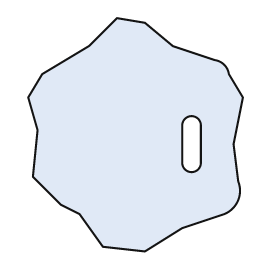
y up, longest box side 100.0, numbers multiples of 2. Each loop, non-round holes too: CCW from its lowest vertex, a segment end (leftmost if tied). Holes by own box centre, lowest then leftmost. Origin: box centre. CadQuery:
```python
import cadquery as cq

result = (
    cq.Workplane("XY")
    .moveTo(4.0, -50.0)
    .lineTo(20.0, -40.0)
    .lineTo(38.0, -34.0)
    .threePointArc((44.0, -28.0), (44.0, -20.0))
    .lineTo(42.0, -4.0)
    .lineTo(46.0, 16.0)
    .lineTo(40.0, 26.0)
    .threePointArc((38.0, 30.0), (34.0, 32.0))
    .lineTo(16.0, 38.0)
    .lineTo(4.0, 48.0)
    .lineTo(-8.0, 50.0)
    .lineTo(-20.0, 38.0)
    .lineTo(-40.0, 26.0)
    .lineTo(-46.0, 16.0)
    .lineTo(-42.0, 2.0)
    .lineTo(-44.0, -18.0)
    .lineTo(-32.0, -30.0)
    .lineTo(-24.0, -34.0)
    .lineTo(-14.0, -48.0)
    .close()
    .moveTo(20.0, -12.0)
    .threePointArc((24.0, -16.0), (28.0, -12.0))
    .lineTo(28.0, 4.0)
    .threePointArc((24.0, 8.0), (20.0, 4.0))
    .close()
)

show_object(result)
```